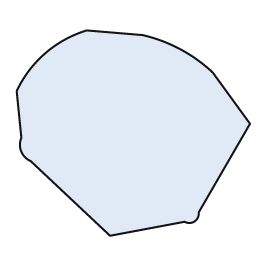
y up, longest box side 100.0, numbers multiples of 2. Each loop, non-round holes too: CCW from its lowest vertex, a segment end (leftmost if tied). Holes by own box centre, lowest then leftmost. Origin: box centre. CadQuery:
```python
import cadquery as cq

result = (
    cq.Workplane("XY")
    .moveTo(-10.0, -44.0)
    .lineTo(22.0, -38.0)
    .threePointArc((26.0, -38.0), (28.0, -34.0))
    .lineTo(50.0, 4.0)
    .lineTo(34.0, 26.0)
    .threePointArc((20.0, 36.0), (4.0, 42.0))
    .lineTo(-20.0, 44.0)
    .threePointArc((-38.0, 34.0), (-50.0, 18.0))
    .lineTo(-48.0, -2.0)
    .threePointArc((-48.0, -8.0), (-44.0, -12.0))
    .close()
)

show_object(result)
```